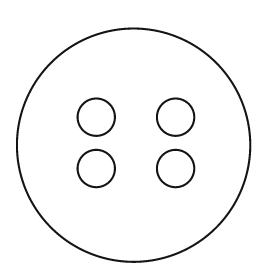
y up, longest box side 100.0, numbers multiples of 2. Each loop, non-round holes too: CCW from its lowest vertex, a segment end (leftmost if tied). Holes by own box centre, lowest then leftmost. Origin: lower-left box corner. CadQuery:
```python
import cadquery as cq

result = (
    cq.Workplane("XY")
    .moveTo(50.0, 50.0)
    .circle(50.0)
    .moveTo(34.0, 40.0)
    .circle(8.0)
    .moveTo(68.0, 40.0)
    .circle(8.0)
    .moveTo(34.0, 62.0)
    .circle(8.0)
    .moveTo(68.0, 62.0)
    .circle(8.0)
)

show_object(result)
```